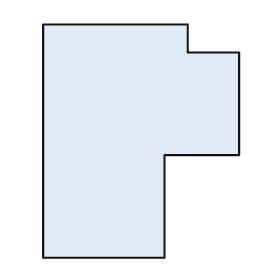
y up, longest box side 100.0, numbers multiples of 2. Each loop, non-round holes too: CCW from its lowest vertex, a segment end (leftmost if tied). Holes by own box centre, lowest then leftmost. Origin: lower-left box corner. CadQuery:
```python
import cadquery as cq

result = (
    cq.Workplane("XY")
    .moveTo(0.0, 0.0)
    .lineTo(52.0, 0.0)
    .lineTo(52.0, 44.0)
    .lineTo(84.0, 44.0)
    .lineTo(84.0, 88.0)
    .lineTo(62.0, 88.0)
    .lineTo(62.0, 100.0)
    .lineTo(0.0, 100.0)
    .close()
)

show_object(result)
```